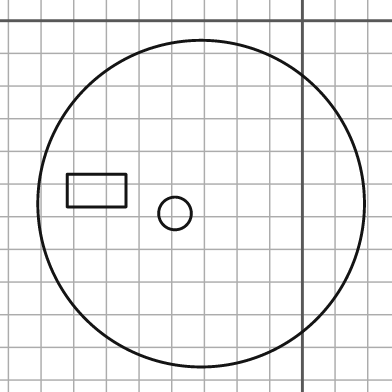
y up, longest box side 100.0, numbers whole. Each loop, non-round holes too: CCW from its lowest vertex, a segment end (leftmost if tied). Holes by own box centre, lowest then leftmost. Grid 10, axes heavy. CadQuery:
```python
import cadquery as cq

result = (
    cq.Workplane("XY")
    .moveTo(-31.0, -56.0)
    .circle(50.0)
    .moveTo(-39.0, -59.0)
    .circle(5.0)
    .moveTo(-72.0, -57.0)
    .lineTo(-54.0, -57.0)
    .lineTo(-54.0, -47.0)
    .lineTo(-72.0, -47.0)
    .close()
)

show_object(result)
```